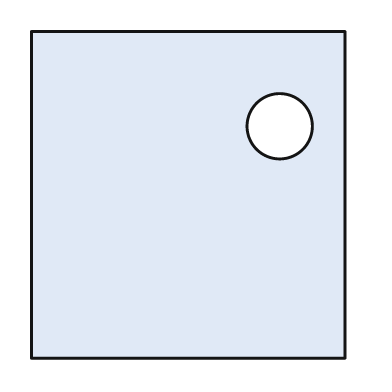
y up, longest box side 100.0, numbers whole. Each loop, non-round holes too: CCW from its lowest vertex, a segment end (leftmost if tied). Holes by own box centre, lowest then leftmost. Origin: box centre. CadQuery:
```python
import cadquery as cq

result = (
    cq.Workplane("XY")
    .moveTo(-48.0, -50.0)
    .lineTo(48.0, -50.0)
    .lineTo(48.0, 50.0)
    .lineTo(-48.0, 50.0)
    .close()
    .moveTo(28.0, 21.0)
    .circle(10.0)
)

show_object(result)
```